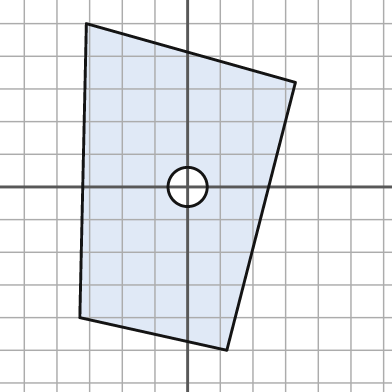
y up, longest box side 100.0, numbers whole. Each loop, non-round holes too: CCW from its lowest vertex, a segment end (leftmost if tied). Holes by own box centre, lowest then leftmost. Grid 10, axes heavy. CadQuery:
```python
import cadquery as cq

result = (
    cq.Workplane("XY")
    .moveTo(12.0, -50.0)
    .lineTo(33.0, 32.0)
    .lineTo(-31.0, 50.0)
    .lineTo(-33.0, -40.0)
    .close()
    .moveTo(0.0, 0.0)
    .circle(6.0)
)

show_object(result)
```